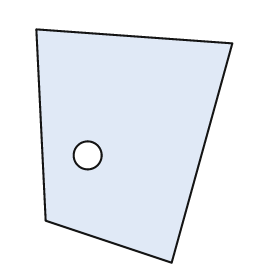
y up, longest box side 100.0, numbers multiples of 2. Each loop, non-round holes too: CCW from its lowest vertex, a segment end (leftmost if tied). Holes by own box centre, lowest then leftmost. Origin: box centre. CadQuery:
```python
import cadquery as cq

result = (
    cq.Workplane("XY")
    .moveTo(16.0, -50.0)
    .lineTo(42.0, 44.0)
    .lineTo(-42.0, 50.0)
    .lineTo(-38.0, -32.0)
    .close()
    .moveTo(-20.0, -4.0)
    .circle(6.0)
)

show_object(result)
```